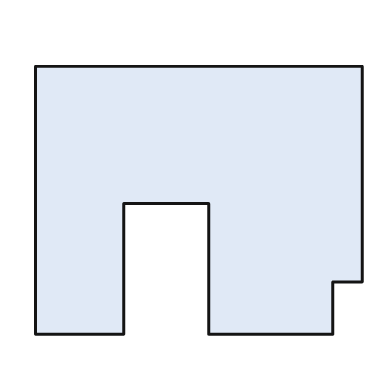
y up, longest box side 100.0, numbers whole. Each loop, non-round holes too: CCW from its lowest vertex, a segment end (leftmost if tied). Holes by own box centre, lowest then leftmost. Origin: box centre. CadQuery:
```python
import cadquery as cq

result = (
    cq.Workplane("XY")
    .moveTo(-50.0, -41.0)
    .lineTo(-23.0, -41.0)
    .lineTo(-23.0, -1.0)
    .lineTo(3.0, -1.0)
    .lineTo(3.0, -41.0)
    .lineTo(41.0, -41.0)
    .lineTo(41.0, -25.0)
    .lineTo(50.0, -25.0)
    .lineTo(50.0, 41.0)
    .lineTo(-50.0, 41.0)
    .close()
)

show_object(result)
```